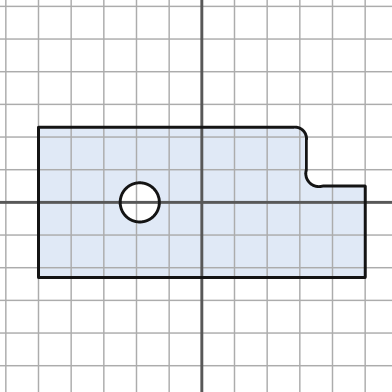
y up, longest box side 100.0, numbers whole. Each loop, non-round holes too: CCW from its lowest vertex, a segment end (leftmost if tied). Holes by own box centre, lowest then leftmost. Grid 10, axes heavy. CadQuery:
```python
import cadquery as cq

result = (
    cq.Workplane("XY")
    .moveTo(-50.0, -23.0)
    .lineTo(50.0, -23.0)
    .lineTo(50.0, 5.0)
    .lineTo(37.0, 5.0)
    .threePointArc((33.0, 6.0), (32.0, 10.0))
    .lineTo(32.0, 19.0)
    .threePointArc((31.0, 22.0), (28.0, 23.0))
    .lineTo(-50.0, 23.0)
    .close()
    .moveTo(-19.0, 0.0)
    .circle(6.0)
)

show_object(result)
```